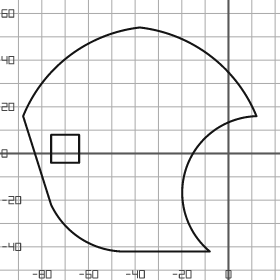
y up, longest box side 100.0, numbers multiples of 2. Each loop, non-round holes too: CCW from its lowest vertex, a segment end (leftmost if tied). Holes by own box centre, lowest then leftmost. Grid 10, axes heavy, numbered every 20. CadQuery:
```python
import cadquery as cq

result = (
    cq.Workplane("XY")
    .moveTo(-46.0, -42.0)
    .lineTo(-8.0, -42.0)
    .threePointArc((-18.0, -6.0), (12.0, 16.0))
    .threePointArc((-8.0, 42.0), (-38.0, 54.0))
    .threePointArc((-68.0, 42.0), (-88.0, 16.0))
    .lineTo(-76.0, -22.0)
    .threePointArc((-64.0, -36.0), (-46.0, -42.0))
    .close()
    .moveTo(-76.0, -4.0)
    .lineTo(-64.0, -4.0)
    .lineTo(-64.0, 8.0)
    .lineTo(-76.0, 8.0)
    .close()
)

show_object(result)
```